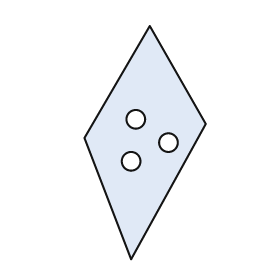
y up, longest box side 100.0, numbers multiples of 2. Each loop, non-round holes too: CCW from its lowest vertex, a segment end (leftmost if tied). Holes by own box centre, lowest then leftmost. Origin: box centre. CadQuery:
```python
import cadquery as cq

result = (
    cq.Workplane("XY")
    .moveTo(-6.0, -50.0)
    .lineTo(26.0, 8.0)
    .lineTo(2.0, 50.0)
    .lineTo(-26.0, 2.0)
    .close()
    .moveTo(-6.0, -8.0)
    .circle(4.0)
    .moveTo(10.0, 0.0)
    .circle(4.0)
    .moveTo(-4.0, 10.0)
    .circle(4.0)
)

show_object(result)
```